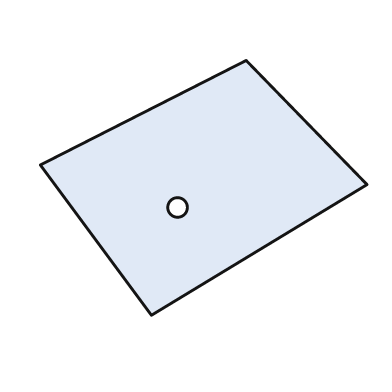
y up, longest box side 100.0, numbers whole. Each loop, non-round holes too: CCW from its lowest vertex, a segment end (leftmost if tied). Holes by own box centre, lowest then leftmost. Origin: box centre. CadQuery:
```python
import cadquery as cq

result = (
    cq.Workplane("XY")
    .moveTo(-16.0, -39.0)
    .lineTo(50.0, 1.0)
    .lineTo(13.0, 39.0)
    .lineTo(-50.0, 7.0)
    .close()
    .moveTo(-8.0, -6.0)
    .circle(3.0)
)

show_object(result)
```